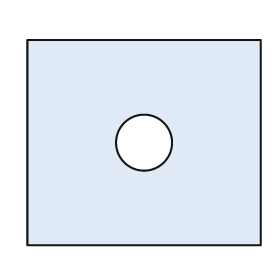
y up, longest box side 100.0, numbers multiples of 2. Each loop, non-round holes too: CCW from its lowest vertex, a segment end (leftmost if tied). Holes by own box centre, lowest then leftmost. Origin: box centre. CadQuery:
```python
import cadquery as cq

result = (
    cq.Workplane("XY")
    .moveTo(-50.0, -44.0)
    .lineTo(50.0, -44.0)
    .lineTo(50.0, 44.0)
    .lineTo(-50.0, 44.0)
    .close()
    .moveTo(0.0, 0.0)
    .circle(12.0)
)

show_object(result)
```